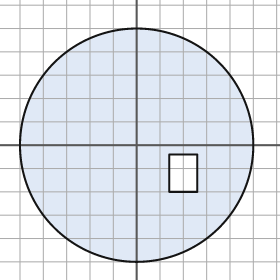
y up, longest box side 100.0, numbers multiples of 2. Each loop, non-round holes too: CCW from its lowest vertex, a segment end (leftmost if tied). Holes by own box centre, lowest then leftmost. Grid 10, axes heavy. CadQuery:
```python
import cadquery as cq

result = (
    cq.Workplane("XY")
    .moveTo(0.0, 0.0)
    .circle(50.0)
    .moveTo(14.0, -20.0)
    .lineTo(26.0, -20.0)
    .lineTo(26.0, -4.0)
    .lineTo(14.0, -4.0)
    .close()
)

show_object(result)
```